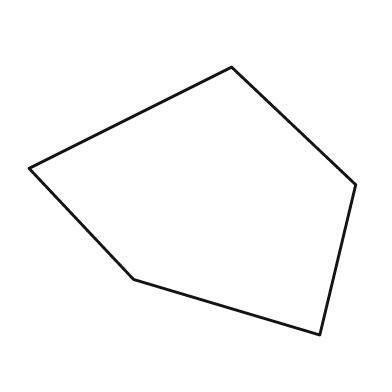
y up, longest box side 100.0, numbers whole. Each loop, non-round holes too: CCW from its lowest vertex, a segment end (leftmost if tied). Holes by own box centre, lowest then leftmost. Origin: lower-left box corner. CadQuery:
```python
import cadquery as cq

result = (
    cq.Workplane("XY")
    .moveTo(89.0, 0.0)
    .lineTo(100.0, 46.0)
    .lineTo(62.0, 82.0)
    .lineTo(0.0, 51.0)
    .lineTo(32.0, 17.0)
    .close()
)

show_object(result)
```